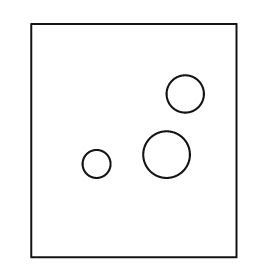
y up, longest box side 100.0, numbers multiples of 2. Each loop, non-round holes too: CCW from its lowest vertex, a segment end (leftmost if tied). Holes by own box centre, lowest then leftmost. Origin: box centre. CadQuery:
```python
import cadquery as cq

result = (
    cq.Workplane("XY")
    .moveTo(-44.0, -50.0)
    .lineTo(44.0, -50.0)
    .lineTo(44.0, 50.0)
    .lineTo(-44.0, 50.0)
    .close()
    .moveTo(-16.0, -10.0)
    .circle(6.0)
    .moveTo(14.0, -6.0)
    .circle(10.0)
    .moveTo(22.0, 20.0)
    .circle(8.0)
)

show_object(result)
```